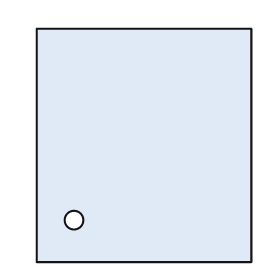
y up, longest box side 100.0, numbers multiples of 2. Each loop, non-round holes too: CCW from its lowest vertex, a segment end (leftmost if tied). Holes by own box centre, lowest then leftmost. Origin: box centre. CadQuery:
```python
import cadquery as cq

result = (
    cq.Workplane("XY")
    .moveTo(-46.0, -50.0)
    .lineTo(46.0, -50.0)
    .lineTo(46.0, 50.0)
    .lineTo(-46.0, 50.0)
    .close()
    .moveTo(-30.0, -32.0)
    .circle(4.0)
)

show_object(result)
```